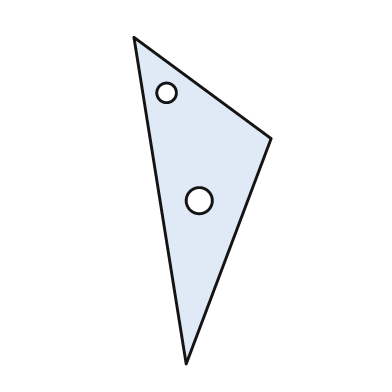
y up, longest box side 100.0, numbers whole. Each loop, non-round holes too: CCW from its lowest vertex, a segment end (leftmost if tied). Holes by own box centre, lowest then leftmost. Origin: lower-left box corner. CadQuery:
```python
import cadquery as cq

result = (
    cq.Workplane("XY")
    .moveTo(16.0, 0.0)
    .lineTo(42.0, 69.0)
    .lineTo(0.0, 100.0)
    .close()
    .moveTo(20.0, 50.0)
    .circle(4.0)
    .moveTo(10.0, 83.0)
    .circle(3.0)
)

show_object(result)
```